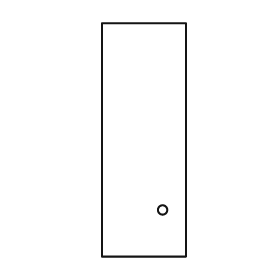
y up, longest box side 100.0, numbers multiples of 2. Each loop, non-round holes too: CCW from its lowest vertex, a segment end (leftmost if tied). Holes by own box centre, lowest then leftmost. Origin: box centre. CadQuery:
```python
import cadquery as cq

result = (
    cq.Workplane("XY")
    .moveTo(-18.0, -50.0)
    .lineTo(18.0, -50.0)
    .lineTo(18.0, 50.0)
    .lineTo(-18.0, 50.0)
    .close()
    .moveTo(8.0, -30.0)
    .circle(2.0)
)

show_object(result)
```